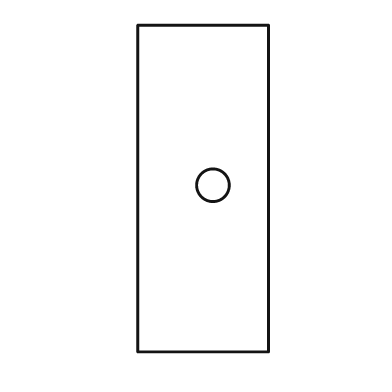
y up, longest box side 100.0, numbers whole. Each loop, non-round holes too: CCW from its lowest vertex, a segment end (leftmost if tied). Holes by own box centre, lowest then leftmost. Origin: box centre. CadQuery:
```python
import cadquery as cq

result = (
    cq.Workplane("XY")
    .moveTo(-20.0, -50.0)
    .lineTo(20.0, -50.0)
    .lineTo(20.0, 50.0)
    .lineTo(-20.0, 50.0)
    .close()
    .moveTo(3.0, 1.0)
    .circle(5.0)
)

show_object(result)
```